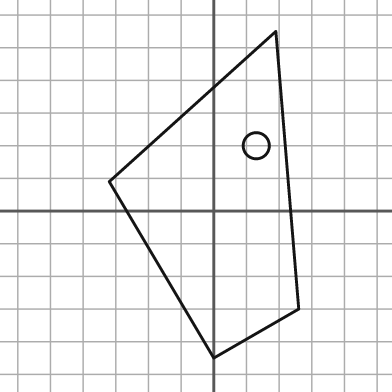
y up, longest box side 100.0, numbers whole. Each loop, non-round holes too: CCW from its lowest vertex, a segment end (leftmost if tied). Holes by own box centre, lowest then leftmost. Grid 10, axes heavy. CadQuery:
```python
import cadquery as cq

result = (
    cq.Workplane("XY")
    .moveTo(0.0, -45.0)
    .lineTo(26.0, -30.0)
    .lineTo(19.0, 55.0)
    .lineTo(-32.0, 9.0)
    .close()
    .moveTo(13.0, 20.0)
    .circle(4.0)
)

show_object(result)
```